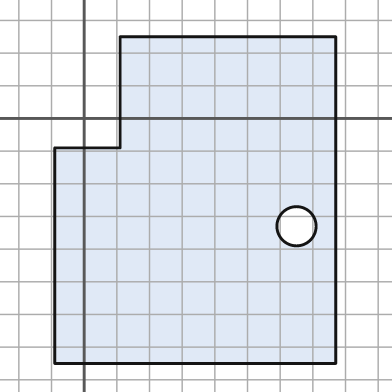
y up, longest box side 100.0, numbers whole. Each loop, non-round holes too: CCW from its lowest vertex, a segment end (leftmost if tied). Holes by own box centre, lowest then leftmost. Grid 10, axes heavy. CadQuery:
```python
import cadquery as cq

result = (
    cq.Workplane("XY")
    .moveTo(-9.0, -75.0)
    .lineTo(77.0, -75.0)
    .lineTo(77.0, 25.0)
    .lineTo(11.0, 25.0)
    .lineTo(11.0, -9.0)
    .lineTo(-9.0, -9.0)
    .close()
    .moveTo(65.0, -33.0)
    .circle(6.0)
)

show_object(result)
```